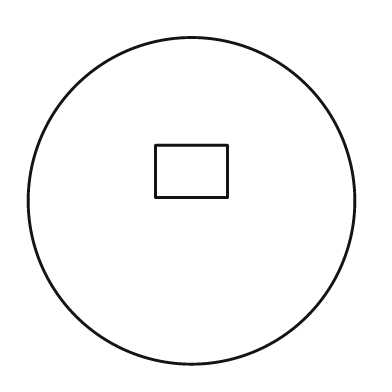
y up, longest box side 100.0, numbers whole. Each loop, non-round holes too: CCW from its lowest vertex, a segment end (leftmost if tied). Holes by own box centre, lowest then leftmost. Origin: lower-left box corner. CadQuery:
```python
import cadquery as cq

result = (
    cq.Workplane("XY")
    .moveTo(50.0, 50.0)
    .circle(50.0)
    .moveTo(39.0, 51.0)
    .lineTo(61.0, 51.0)
    .lineTo(61.0, 67.0)
    .lineTo(39.0, 67.0)
    .close()
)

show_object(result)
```